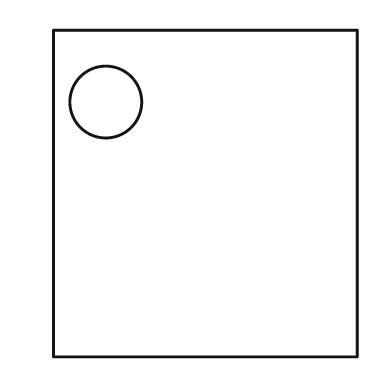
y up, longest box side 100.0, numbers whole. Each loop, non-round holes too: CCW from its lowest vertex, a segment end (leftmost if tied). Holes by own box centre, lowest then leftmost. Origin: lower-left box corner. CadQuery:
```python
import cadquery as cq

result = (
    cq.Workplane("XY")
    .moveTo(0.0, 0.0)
    .lineTo(93.0, 0.0)
    .lineTo(93.0, 100.0)
    .lineTo(0.0, 100.0)
    .close()
    .moveTo(16.0, 78.0)
    .circle(11.0)
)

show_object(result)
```